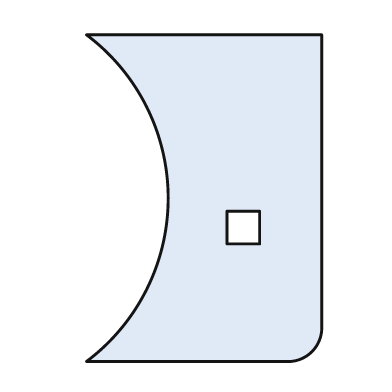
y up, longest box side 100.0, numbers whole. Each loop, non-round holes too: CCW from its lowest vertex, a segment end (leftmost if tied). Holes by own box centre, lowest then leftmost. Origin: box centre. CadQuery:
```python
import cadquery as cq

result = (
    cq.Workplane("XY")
    .moveTo(-36.0, -50.0)
    .lineTo(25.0, -50.0)
    .threePointArc((33.0, -47.0), (36.0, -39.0))
    .lineTo(36.0, 50.0)
    .lineTo(-36.0, 50.0)
    .threePointArc((-11.0, 0.0), (-36.0, -50.0))
    .close()
    .moveTo(7.0, -14.0)
    .lineTo(17.0, -14.0)
    .lineTo(17.0, -4.0)
    .lineTo(7.0, -4.0)
    .close()
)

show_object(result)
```